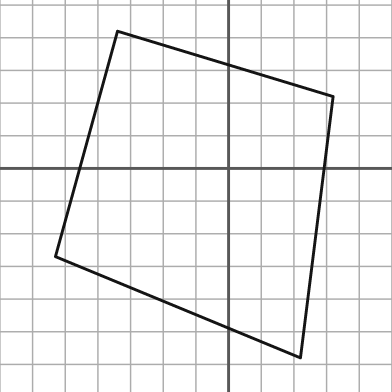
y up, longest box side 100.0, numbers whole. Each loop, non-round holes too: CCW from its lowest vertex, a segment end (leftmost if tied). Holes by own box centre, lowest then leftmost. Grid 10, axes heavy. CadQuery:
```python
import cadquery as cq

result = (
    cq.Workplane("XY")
    .moveTo(22.0, -58.0)
    .lineTo(32.0, 22.0)
    .lineTo(-34.0, 42.0)
    .lineTo(-53.0, -27.0)
    .close()
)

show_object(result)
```